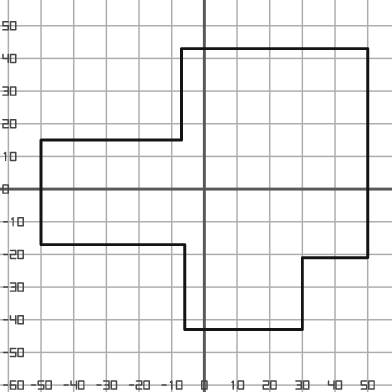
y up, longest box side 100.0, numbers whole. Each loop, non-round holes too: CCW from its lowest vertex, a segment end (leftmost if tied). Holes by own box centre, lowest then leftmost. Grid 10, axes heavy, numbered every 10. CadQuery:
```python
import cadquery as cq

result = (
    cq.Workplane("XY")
    .moveTo(-6.0, -43.0)
    .lineTo(30.0, -43.0)
    .lineTo(30.0, -21.0)
    .lineTo(50.0, -21.0)
    .lineTo(50.0, 43.0)
    .lineTo(-7.0, 43.0)
    .lineTo(-7.0, 15.0)
    .lineTo(-50.0, 15.0)
    .lineTo(-50.0, -17.0)
    .lineTo(-6.0, -17.0)
    .close()
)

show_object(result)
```